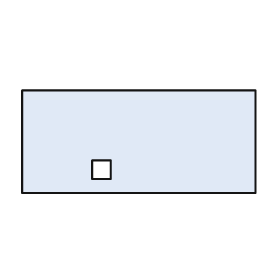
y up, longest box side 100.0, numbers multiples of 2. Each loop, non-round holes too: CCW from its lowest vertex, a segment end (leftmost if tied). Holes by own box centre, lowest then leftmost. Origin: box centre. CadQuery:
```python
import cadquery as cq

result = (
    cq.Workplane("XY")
    .moveTo(-50.0, -22.0)
    .lineTo(50.0, -22.0)
    .lineTo(50.0, 22.0)
    .lineTo(-50.0, 22.0)
    .close()
    .moveTo(-20.0, -16.0)
    .lineTo(-12.0, -16.0)
    .lineTo(-12.0, -8.0)
    .lineTo(-20.0, -8.0)
    .close()
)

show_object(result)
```